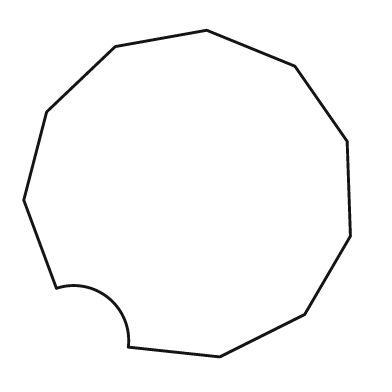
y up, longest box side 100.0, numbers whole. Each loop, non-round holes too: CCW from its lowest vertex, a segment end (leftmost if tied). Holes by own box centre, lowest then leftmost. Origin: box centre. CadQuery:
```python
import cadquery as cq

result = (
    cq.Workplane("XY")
    .moveTo(10.0, -50.0)
    .lineTo(36.0, -37.0)
    .lineTo(50.0, -13.0)
    .lineTo(49.0, 16.0)
    .lineTo(33.0, 39.0)
    .lineTo(6.0, 50.0)
    .lineTo(-22.0, 45.0)
    .lineTo(-43.0, 25.0)
    .lineTo(-50.0, -2.0)
    .lineTo(-40.0, -29.0)
    .threePointArc((-24.0, -32.0), (-18.0, -47.0))
    .close()
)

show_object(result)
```